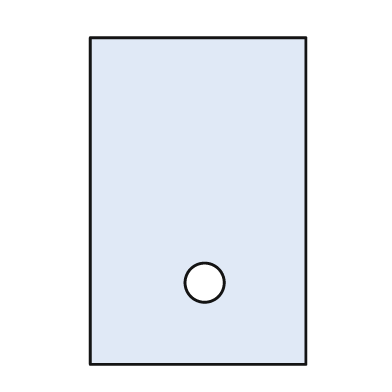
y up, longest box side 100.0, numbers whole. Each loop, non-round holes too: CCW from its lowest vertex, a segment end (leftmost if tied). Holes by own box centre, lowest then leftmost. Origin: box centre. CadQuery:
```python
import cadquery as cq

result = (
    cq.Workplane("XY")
    .moveTo(-33.0, -50.0)
    .lineTo(33.0, -50.0)
    .lineTo(33.0, 50.0)
    .lineTo(-33.0, 50.0)
    .close()
    .moveTo(2.0, -25.0)
    .circle(6.0)
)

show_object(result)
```